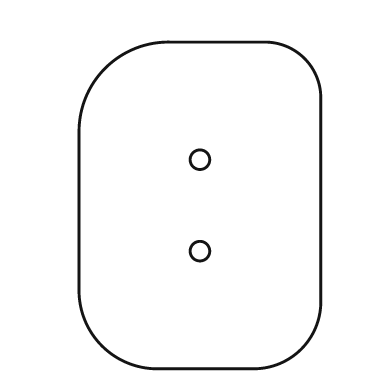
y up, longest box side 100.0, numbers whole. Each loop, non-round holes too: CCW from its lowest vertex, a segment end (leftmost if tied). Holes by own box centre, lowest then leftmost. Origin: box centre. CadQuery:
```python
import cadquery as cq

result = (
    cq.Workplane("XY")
    .moveTo(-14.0, -50.0)
    .lineTo(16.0, -50.0)
    .threePointArc((31.0, -44.0), (37.0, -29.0))
    .lineTo(37.0, 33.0)
    .threePointArc((32.0, 45.0), (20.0, 50.0))
    .lineTo(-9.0, 50.0)
    .threePointArc((-29.0, 42.0), (-37.0, 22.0))
    .lineTo(-37.0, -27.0)
    .threePointArc((-30.0, -43.0), (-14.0, -50.0))
    .close()
    .moveTo(0.0, -14.0)
    .circle(3.0)
    .moveTo(0.0, 14.0)
    .circle(3.0)
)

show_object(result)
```